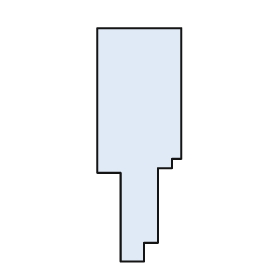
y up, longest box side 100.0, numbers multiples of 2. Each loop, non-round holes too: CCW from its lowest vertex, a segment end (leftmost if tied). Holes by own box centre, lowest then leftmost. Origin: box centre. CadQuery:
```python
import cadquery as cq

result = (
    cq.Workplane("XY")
    .moveTo(-8.0, -50.0)
    .lineTo(2.0, -50.0)
    .lineTo(2.0, -42.0)
    .lineTo(8.0, -42.0)
    .lineTo(8.0, -10.0)
    .lineTo(14.0, -10.0)
    .lineTo(14.0, -6.0)
    .lineTo(18.0, -6.0)
    .lineTo(18.0, 50.0)
    .lineTo(-18.0, 50.0)
    .lineTo(-18.0, -12.0)
    .lineTo(-8.0, -12.0)
    .close()
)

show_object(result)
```